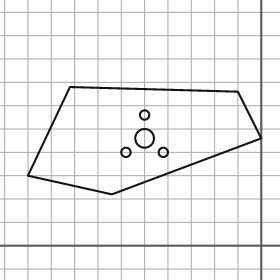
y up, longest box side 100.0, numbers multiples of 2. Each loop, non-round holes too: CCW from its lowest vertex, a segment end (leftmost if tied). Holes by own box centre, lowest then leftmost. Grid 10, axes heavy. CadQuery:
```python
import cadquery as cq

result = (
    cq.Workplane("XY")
    .moveTo(-64.0, 22.0)
    .lineTo(0.0, 46.0)
    .lineTo(-10.0, 66.0)
    .lineTo(-82.0, 68.0)
    .lineTo(-100.0, 30.0)
    .close()
    .moveTo(-58.0, 40.0)
    .circle(2.0)
    .moveTo(-42.0, 40.0)
    .circle(2.0)
    .moveTo(-50.0, 46.0)
    .circle(4.0)
    .moveTo(-50.0, 56.0)
    .circle(2.0)
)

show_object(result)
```